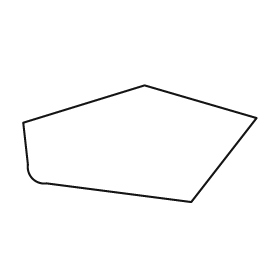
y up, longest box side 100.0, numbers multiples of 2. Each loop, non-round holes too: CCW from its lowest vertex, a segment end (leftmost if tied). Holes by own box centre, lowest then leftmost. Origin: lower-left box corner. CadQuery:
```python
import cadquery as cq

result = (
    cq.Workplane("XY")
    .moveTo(72.0, 0.0)
    .lineTo(100.0, 36.0)
    .lineTo(52.0, 50.0)
    .lineTo(0.0, 34.0)
    .lineTo(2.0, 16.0)
    .threePointArc((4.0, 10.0), (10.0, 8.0))
    .close()
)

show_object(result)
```